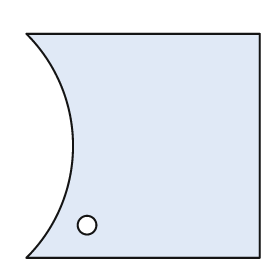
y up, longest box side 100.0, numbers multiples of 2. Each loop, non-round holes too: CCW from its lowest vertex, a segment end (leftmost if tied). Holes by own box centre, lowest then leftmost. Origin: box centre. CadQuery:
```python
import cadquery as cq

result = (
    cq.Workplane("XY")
    .moveTo(-50.0, -48.0)
    .lineTo(50.0, -48.0)
    .lineTo(50.0, 48.0)
    .lineTo(-50.0, 48.0)
    .threePointArc((-30.0, 0.0), (-50.0, -48.0))
    .close()
    .moveTo(-24.0, -34.0)
    .circle(4.0)
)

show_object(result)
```